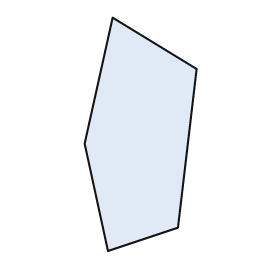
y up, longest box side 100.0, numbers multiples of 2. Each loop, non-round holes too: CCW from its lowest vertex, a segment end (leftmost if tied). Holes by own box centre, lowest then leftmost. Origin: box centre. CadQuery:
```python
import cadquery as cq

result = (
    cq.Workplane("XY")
    .moveTo(-14.0, -50.0)
    .lineTo(16.0, -40.0)
    .lineTo(24.0, 28.0)
    .lineTo(-12.0, 50.0)
    .lineTo(-24.0, -4.0)
    .close()
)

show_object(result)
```